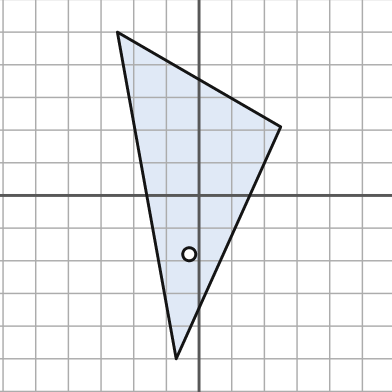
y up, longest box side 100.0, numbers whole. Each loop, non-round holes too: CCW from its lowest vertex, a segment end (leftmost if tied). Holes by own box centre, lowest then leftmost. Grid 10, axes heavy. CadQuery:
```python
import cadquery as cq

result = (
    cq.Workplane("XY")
    .moveTo(-7.0, -50.0)
    .lineTo(25.0, 21.0)
    .lineTo(-25.0, 50.0)
    .close()
    .moveTo(-3.0, -18.0)
    .circle(2.0)
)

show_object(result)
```